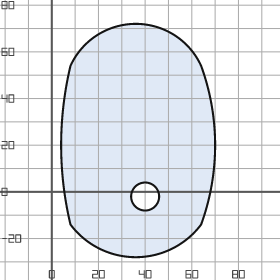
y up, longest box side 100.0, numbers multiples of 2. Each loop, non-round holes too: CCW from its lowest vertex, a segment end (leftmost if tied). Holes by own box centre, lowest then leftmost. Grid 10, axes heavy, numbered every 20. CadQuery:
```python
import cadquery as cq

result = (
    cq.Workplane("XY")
    .moveTo(8.0, -14.0)
    .threePointArc((36.0, -28.0), (64.0, -14.0))
    .threePointArc((70.0, 20.0), (64.0, 54.0))
    .threePointArc((36.0, 72.0), (8.0, 54.0))
    .threePointArc((4.0, 20.0), (8.0, -14.0))
    .close()
    .moveTo(40.0, -2.0)
    .circle(6.0)
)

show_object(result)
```